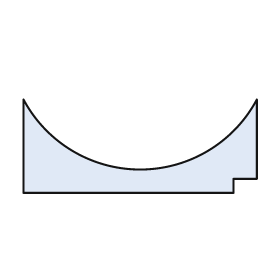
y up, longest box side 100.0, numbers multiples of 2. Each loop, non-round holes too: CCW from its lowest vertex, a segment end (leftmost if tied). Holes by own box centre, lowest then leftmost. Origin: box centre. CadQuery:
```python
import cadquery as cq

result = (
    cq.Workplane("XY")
    .moveTo(-50.0, -20.0)
    .lineTo(40.0, -20.0)
    .lineTo(40.0, -14.0)
    .lineTo(50.0, -14.0)
    .lineTo(50.0, 20.0)
    .threePointArc((0.0, -10.0), (-50.0, 20.0))
    .close()
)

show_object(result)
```